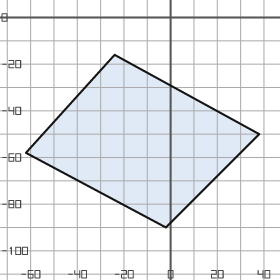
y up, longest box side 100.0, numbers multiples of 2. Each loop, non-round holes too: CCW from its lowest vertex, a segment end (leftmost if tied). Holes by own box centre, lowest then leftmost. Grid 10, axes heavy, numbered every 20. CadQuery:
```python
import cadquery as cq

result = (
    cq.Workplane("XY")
    .moveTo(-2.0, -90.0)
    .lineTo(38.0, -50.0)
    .lineTo(-24.0, -16.0)
    .lineTo(-62.0, -58.0)
    .close()
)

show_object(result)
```